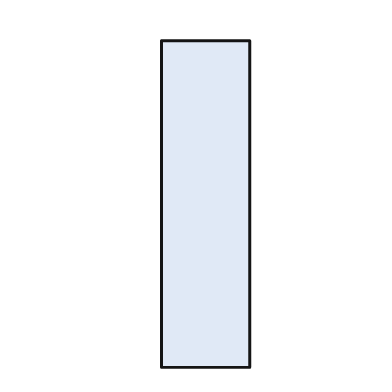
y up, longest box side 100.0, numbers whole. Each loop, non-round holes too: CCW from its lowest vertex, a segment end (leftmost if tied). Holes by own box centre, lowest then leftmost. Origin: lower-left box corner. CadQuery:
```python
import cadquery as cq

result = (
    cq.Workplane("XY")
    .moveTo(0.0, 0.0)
    .lineTo(27.0, 0.0)
    .lineTo(27.0, 100.0)
    .lineTo(0.0, 100.0)
    .close()
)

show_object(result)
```